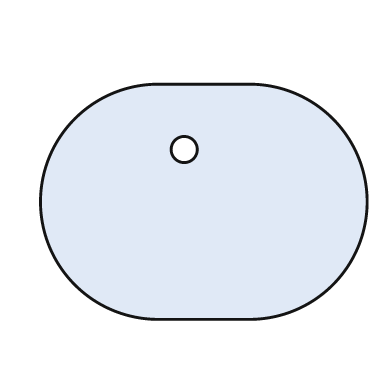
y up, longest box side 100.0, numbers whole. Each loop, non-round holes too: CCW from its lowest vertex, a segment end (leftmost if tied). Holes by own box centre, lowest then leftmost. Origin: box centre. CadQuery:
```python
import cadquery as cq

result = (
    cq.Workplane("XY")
    .moveTo(-14.0, -36.0)
    .lineTo(14.0, -36.0)
    .threePointArc((50.0, 0.0), (14.0, 36.0))
    .lineTo(-14.0, 36.0)
    .threePointArc((-50.0, 0.0), (-14.0, -36.0))
    .close()
    .moveTo(-6.0, 16.0)
    .circle(4.0)
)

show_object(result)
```